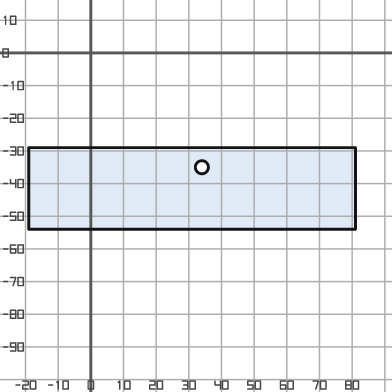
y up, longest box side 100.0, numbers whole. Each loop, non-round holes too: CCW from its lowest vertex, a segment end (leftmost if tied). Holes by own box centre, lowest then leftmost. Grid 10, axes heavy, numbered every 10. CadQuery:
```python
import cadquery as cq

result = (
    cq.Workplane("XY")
    .moveTo(-19.0, -54.0)
    .lineTo(81.0, -54.0)
    .lineTo(81.0, -29.0)
    .lineTo(-19.0, -29.0)
    .close()
    .moveTo(34.0, -35.0)
    .circle(2.0)
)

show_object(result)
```